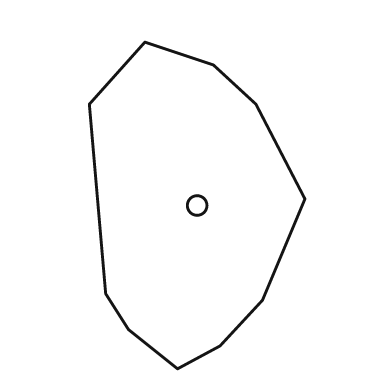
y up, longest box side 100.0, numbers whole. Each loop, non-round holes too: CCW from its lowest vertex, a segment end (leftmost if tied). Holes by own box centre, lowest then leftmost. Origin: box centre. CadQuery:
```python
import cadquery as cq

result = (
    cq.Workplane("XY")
    .moveTo(-6.0, -50.0)
    .lineTo(7.0, -43.0)
    .lineTo(20.0, -29.0)
    .lineTo(33.0, 2.0)
    .lineTo(18.0, 31.0)
    .lineTo(5.0, 43.0)
    .lineTo(-16.0, 50.0)
    .lineTo(-33.0, 31.0)
    .lineTo(-28.0, -27.0)
    .lineTo(-21.0, -38.0)
    .close()
    .moveTo(0.0, 0.0)
    .circle(3.0)
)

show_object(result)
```